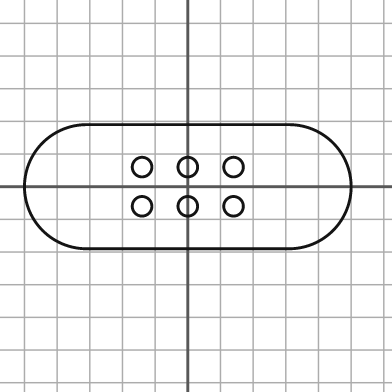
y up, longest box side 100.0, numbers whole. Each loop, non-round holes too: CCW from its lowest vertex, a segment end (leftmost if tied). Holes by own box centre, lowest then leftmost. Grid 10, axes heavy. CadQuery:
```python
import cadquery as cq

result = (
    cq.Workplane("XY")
    .moveTo(-31.0, -19.0)
    .lineTo(31.0, -19.0)
    .threePointArc((50.0, 0.0), (31.0, 19.0))
    .lineTo(-31.0, 19.0)
    .threePointArc((-50.0, 0.0), (-31.0, -19.0))
    .close()
    .moveTo(-14.0, -6.0)
    .circle(3.0)
    .moveTo(0.0, -6.0)
    .circle(3.0)
    .moveTo(14.0, -6.0)
    .circle(3.0)
    .moveTo(-14.0, 6.0)
    .circle(3.0)
    .moveTo(0.0, 6.0)
    .circle(3.0)
    .moveTo(14.0, 6.0)
    .circle(3.0)
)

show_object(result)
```